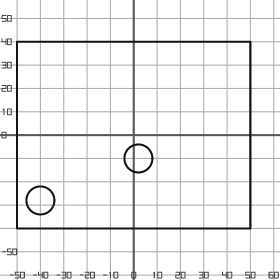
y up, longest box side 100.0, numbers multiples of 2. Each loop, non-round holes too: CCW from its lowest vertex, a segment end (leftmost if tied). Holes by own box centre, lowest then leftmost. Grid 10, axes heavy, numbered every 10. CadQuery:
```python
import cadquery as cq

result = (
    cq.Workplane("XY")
    .moveTo(-50.0, -40.0)
    .lineTo(50.0, -40.0)
    .lineTo(50.0, 40.0)
    .lineTo(-50.0, 40.0)
    .close()
    .moveTo(-40.0, -28.0)
    .circle(6.0)
    .moveTo(2.0, -10.0)
    .circle(6.0)
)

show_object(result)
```